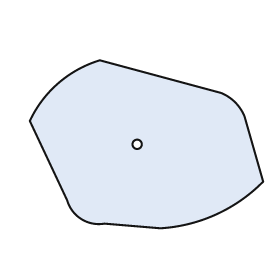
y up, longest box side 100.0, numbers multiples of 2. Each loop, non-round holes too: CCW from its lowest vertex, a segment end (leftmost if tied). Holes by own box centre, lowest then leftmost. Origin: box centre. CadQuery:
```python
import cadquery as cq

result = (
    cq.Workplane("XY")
    .moveTo(6.0, -36.0)
    .threePointArc((30.0, -30.0), (50.0, -16.0))
    .lineTo(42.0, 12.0)
    .threePointArc((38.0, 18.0), (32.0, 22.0))
    .lineTo(-20.0, 36.0)
    .threePointArc((-38.0, 26.0), (-50.0, 10.0))
    .lineTo(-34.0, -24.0)
    .threePointArc((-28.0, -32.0), (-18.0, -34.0))
    .close()
    .moveTo(-4.0, 0.0)
    .circle(2.0)
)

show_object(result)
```